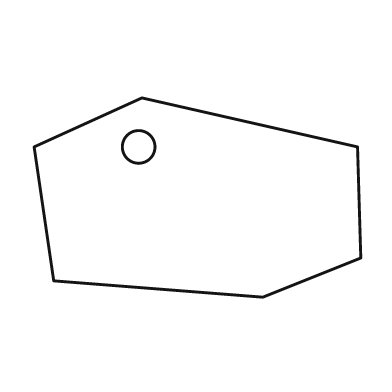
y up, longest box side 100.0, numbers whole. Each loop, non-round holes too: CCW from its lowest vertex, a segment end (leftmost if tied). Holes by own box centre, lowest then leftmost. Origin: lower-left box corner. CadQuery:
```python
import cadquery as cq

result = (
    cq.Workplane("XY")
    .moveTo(70.0, 0.0)
    .lineTo(100.0, 12.0)
    .lineTo(99.0, 46.0)
    .lineTo(33.0, 61.0)
    .lineTo(0.0, 46.0)
    .lineTo(6.0, 5.0)
    .close()
    .moveTo(32.0, 46.0)
    .circle(5.0)
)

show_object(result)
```